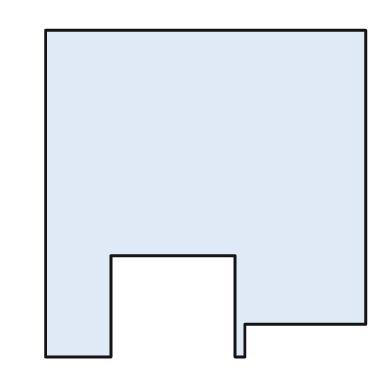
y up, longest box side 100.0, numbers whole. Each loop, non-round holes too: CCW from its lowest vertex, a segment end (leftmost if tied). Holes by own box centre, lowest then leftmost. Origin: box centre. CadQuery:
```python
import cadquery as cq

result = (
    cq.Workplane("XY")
    .moveTo(-49.0, -50.0)
    .lineTo(-29.0, -50.0)
    .lineTo(-29.0, -19.0)
    .lineTo(9.0, -19.0)
    .lineTo(9.0, -50.0)
    .lineTo(12.0, -50.0)
    .lineTo(12.0, -40.0)
    .lineTo(49.0, -40.0)
    .lineTo(49.0, 50.0)
    .lineTo(-49.0, 50.0)
    .close()
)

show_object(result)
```